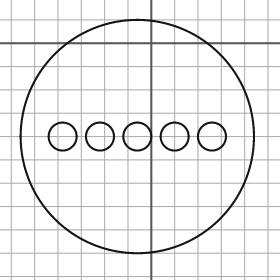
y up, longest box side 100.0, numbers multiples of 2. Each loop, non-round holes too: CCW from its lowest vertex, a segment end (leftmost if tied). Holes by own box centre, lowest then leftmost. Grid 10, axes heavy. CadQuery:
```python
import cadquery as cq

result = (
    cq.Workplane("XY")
    .moveTo(-6.0, -40.0)
    .circle(50.0)
    .moveTo(-38.0, -40.0)
    .circle(6.0)
    .moveTo(-22.0, -40.0)
    .circle(6.0)
    .moveTo(-6.0, -40.0)
    .circle(6.0)
    .moveTo(10.0, -40.0)
    .circle(6.0)
    .moveTo(26.0, -40.0)
    .circle(6.0)
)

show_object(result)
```